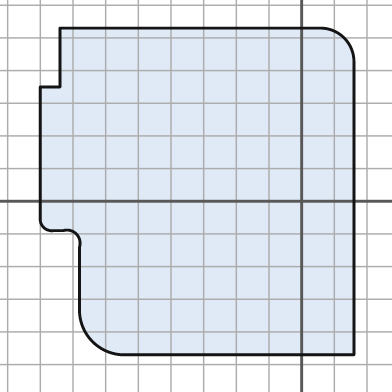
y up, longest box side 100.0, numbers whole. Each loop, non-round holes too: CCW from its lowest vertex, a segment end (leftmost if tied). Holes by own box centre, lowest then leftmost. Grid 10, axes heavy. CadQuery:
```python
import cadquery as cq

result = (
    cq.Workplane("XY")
    .moveTo(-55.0, -47.0)
    .lineTo(16.0, -47.0)
    .lineTo(16.0, 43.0)
    .threePointArc((13.0, 50.0), (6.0, 53.0))
    .lineTo(-74.0, 53.0)
    .lineTo(-74.0, 35.0)
    .lineTo(-80.0, 35.0)
    .lineTo(-80.0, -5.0)
    .threePointArc((-79.0, -8.0), (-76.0, -9.0))
    .lineTo(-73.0, -9.0)
    .threePointArc((-69.0, -10.0), (-68.0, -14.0))
    .lineTo(-68.0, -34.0)
    .threePointArc((-64.0, -43.0), (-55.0, -47.0))
    .close()
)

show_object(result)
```